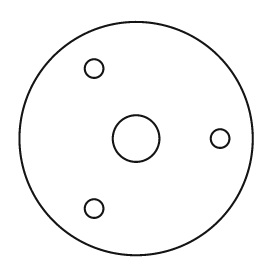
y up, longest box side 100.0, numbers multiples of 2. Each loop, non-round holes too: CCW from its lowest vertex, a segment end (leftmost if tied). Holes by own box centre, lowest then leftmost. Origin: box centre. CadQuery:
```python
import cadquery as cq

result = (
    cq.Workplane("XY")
    .moveTo(0.0, 0.0)
    .circle(50.0)
    .moveTo(-18.0, -30.0)
    .circle(4.0)
    .moveTo(0.0, 0.0)
    .circle(10.0)
    .moveTo(36.0, 0.0)
    .circle(4.0)
    .moveTo(-18.0, 30.0)
    .circle(4.0)
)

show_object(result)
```